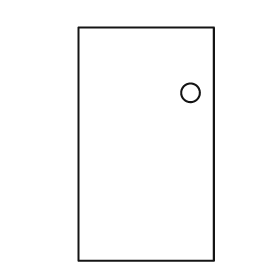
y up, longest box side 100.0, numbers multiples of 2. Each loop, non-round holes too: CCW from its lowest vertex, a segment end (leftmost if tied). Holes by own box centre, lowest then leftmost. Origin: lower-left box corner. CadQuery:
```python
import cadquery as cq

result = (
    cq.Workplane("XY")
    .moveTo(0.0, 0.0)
    .lineTo(58.0, 0.0)
    .lineTo(58.0, 100.0)
    .lineTo(0.0, 100.0)
    .close()
    .moveTo(48.0, 72.0)
    .circle(4.0)
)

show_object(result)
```